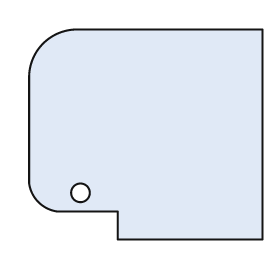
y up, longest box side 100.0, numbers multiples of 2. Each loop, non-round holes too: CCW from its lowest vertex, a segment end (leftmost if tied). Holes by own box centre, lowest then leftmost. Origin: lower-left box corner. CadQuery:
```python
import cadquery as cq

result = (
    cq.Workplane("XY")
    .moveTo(38.0, 0.0)
    .lineTo(100.0, 0.0)
    .lineTo(100.0, 90.0)
    .lineTo(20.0, 90.0)
    .threePointArc((6.0, 84.0), (0.0, 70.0))
    .lineTo(0.0, 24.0)
    .threePointArc((4.0, 16.0), (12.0, 12.0))
    .lineTo(38.0, 12.0)
    .close()
    .moveTo(22.0, 20.0)
    .circle(4.0)
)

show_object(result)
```